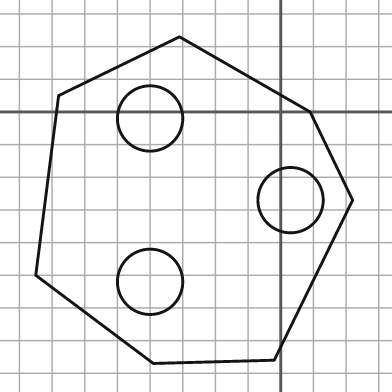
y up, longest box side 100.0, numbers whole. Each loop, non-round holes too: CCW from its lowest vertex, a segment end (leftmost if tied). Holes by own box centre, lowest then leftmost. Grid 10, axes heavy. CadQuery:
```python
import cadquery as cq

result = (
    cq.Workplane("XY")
    .moveTo(-39.0, -77.0)
    .lineTo(-2.0, -76.0)
    .lineTo(22.0, -27.0)
    .lineTo(9.0, 0.0)
    .lineTo(-31.0, 23.0)
    .lineTo(-68.0, 5.0)
    .lineTo(-75.0, -50.0)
    .close()
    .moveTo(-40.0, -52.0)
    .circle(10.0)
    .moveTo(3.0, -27.0)
    .circle(10.0)
    .moveTo(-40.0, -2.0)
    .circle(10.0)
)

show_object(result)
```